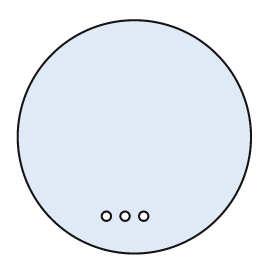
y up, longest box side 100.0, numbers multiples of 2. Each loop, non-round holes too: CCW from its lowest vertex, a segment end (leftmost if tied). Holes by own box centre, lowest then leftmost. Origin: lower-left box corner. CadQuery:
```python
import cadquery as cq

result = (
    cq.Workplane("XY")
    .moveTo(50.0, 50.0)
    .circle(50.0)
    .moveTo(38.0, 16.0)
    .circle(2.0)
    .moveTo(46.0, 16.0)
    .circle(2.0)
    .moveTo(54.0, 16.0)
    .circle(2.0)
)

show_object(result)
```